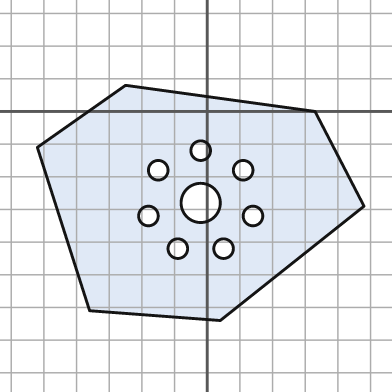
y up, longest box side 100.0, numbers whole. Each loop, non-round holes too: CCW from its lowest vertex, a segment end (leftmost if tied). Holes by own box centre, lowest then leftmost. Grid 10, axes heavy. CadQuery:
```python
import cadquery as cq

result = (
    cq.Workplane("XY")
    .moveTo(4.0, -64.0)
    .lineTo(48.0, -29.0)
    .lineTo(33.0, 0.0)
    .lineTo(-25.0, 8.0)
    .lineTo(-52.0, -11.0)
    .lineTo(-36.0, -61.0)
    .close()
    .moveTo(-9.0, -42.0)
    .circle(3.0)
    .moveTo(5.0, -42.0)
    .circle(3.0)
    .moveTo(-18.0, -32.0)
    .circle(3.0)
    .moveTo(14.0, -32.0)
    .circle(3.0)
    .moveTo(-2.0, -28.0)
    .circle(6.0)
    .moveTo(-15.0, -18.0)
    .circle(3.0)
    .moveTo(11.0, -18.0)
    .circle(3.0)
    .moveTo(-2.0, -12.0)
    .circle(3.0)
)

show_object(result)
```